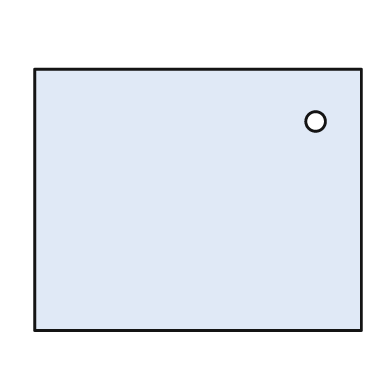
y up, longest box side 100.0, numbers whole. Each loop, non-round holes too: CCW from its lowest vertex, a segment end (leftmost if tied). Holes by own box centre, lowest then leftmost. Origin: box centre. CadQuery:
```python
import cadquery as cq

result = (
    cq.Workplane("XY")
    .moveTo(-50.0, -40.0)
    .lineTo(50.0, -40.0)
    .lineTo(50.0, 40.0)
    .lineTo(-50.0, 40.0)
    .close()
    .moveTo(36.0, 24.0)
    .circle(3.0)
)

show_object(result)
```